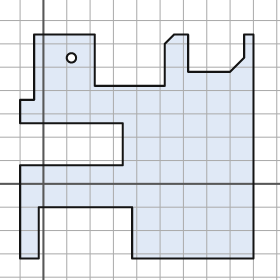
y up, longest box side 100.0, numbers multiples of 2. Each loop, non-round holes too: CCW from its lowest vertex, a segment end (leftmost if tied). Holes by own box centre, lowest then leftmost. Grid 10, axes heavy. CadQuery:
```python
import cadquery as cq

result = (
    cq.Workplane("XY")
    .moveTo(-10.0, -32.0)
    .lineTo(-2.0, -32.0)
    .lineTo(-2.0, -10.0)
    .lineTo(38.0, -10.0)
    .lineTo(38.0, -32.0)
    .lineTo(90.0, -32.0)
    .lineTo(90.0, 64.0)
    .lineTo(86.0, 64.0)
    .lineTo(86.0, 54.0)
    .lineTo(80.0, 48.0)
    .lineTo(62.0, 48.0)
    .lineTo(62.0, 64.0)
    .lineTo(56.0, 64.0)
    .lineTo(52.0, 60.0)
    .lineTo(52.0, 42.0)
    .lineTo(22.0, 42.0)
    .lineTo(22.0, 64.0)
    .lineTo(-4.0, 64.0)
    .lineTo(-4.0, 36.0)
    .lineTo(-10.0, 36.0)
    .lineTo(-10.0, 26.0)
    .lineTo(34.0, 26.0)
    .lineTo(34.0, 8.0)
    .lineTo(-10.0, 8.0)
    .close()
    .moveTo(12.0, 54.0)
    .circle(2.0)
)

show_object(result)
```